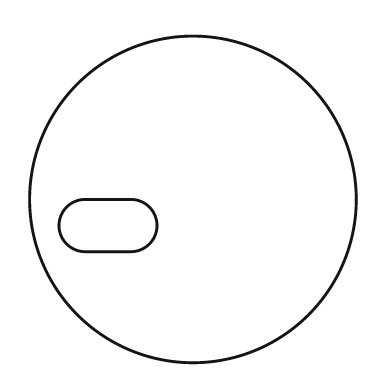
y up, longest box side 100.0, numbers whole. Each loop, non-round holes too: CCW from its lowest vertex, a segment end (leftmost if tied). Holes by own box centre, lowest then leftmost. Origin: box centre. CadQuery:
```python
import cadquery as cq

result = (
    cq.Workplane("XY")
    .moveTo(0.0, 0.0)
    .circle(50.0)
    .moveTo(-33.0, -16.0)
    .lineTo(-19.0, -16.0)
    .threePointArc((-11.0, -8.0), (-19.0, 0.0))
    .lineTo(-33.0, 0.0)
    .threePointArc((-41.0, -8.0), (-33.0, -16.0))
    .close()
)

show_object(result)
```